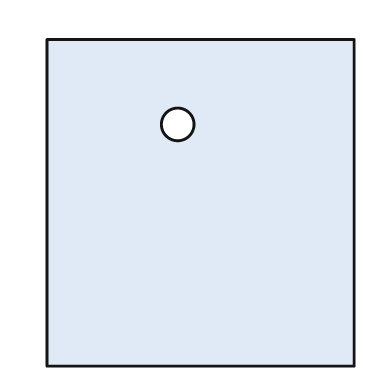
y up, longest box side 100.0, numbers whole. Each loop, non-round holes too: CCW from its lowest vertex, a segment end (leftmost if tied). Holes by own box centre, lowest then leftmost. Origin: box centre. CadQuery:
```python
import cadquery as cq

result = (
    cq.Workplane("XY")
    .moveTo(-47.0, -50.0)
    .lineTo(47.0, -50.0)
    .lineTo(47.0, 50.0)
    .lineTo(-47.0, 50.0)
    .close()
    .moveTo(-7.0, 24.0)
    .circle(5.0)
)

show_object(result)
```